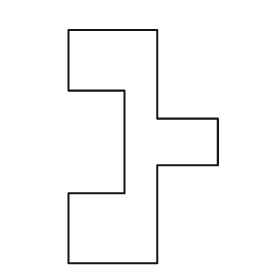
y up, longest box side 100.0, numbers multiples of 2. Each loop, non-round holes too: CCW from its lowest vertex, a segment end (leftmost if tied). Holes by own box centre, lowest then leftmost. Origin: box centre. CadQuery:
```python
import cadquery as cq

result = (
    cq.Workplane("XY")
    .moveTo(-32.0, -50.0)
    .lineTo(6.0, -50.0)
    .lineTo(6.0, -8.0)
    .lineTo(32.0, -8.0)
    .lineTo(32.0, 12.0)
    .lineTo(6.0, 12.0)
    .lineTo(6.0, 50.0)
    .lineTo(-32.0, 50.0)
    .lineTo(-32.0, 24.0)
    .lineTo(-8.0, 24.0)
    .lineTo(-8.0, -20.0)
    .lineTo(-32.0, -20.0)
    .close()
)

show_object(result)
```